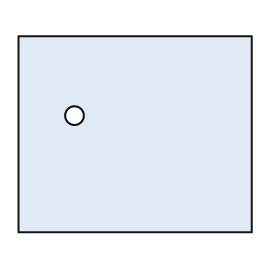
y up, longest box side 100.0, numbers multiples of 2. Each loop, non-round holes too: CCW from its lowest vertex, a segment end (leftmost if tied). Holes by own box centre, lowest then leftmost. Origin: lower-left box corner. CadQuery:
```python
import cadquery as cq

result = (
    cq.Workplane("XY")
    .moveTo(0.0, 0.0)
    .lineTo(100.0, 0.0)
    .lineTo(100.0, 84.0)
    .lineTo(0.0, 84.0)
    .close()
    .moveTo(24.0, 50.0)
    .circle(4.0)
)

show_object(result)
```